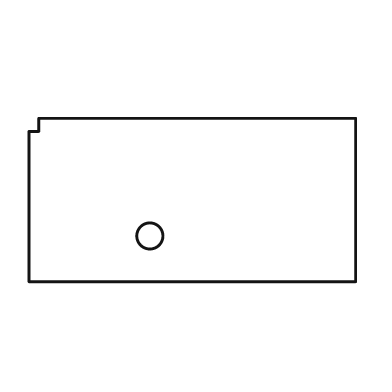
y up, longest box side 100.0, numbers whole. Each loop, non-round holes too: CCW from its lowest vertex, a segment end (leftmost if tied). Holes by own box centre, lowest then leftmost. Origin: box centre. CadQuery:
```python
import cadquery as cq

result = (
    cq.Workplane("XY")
    .moveTo(-50.0, -25.0)
    .lineTo(50.0, -25.0)
    .lineTo(50.0, 25.0)
    .lineTo(-47.0, 25.0)
    .lineTo(-47.0, 21.0)
    .lineTo(-50.0, 21.0)
    .close()
    .moveTo(-13.0, -11.0)
    .circle(4.0)
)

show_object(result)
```